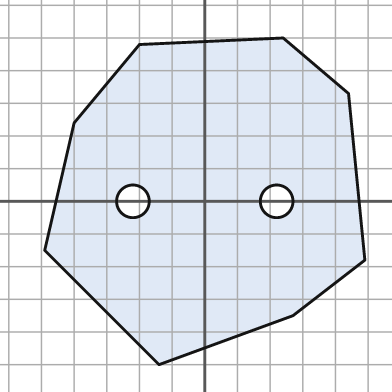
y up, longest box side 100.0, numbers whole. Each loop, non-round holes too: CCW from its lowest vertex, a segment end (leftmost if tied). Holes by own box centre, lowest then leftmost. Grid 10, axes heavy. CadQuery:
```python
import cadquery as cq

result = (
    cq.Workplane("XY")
    .moveTo(-14.0, -50.0)
    .lineTo(27.0, -35.0)
    .lineTo(49.0, -18.0)
    .lineTo(44.0, 33.0)
    .lineTo(24.0, 50.0)
    .lineTo(-20.0, 48.0)
    .lineTo(-40.0, 24.0)
    .lineTo(-49.0, -15.0)
    .close()
    .moveTo(-22.0, 0.0)
    .circle(5.0)
    .moveTo(22.0, 0.0)
    .circle(5.0)
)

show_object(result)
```